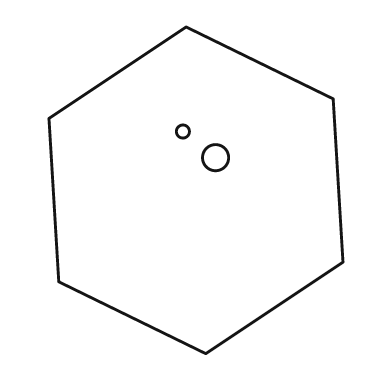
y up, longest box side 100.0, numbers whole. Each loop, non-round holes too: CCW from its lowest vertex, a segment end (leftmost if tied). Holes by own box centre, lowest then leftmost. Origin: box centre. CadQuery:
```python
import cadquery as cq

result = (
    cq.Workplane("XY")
    .moveTo(3.0, -50.0)
    .lineTo(45.0, -22.0)
    .lineTo(42.0, 28.0)
    .lineTo(-3.0, 50.0)
    .lineTo(-45.0, 22.0)
    .lineTo(-42.0, -28.0)
    .close()
    .moveTo(6.0, 10.0)
    .circle(4.0)
    .moveTo(-4.0, 18.0)
    .circle(2.0)
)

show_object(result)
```